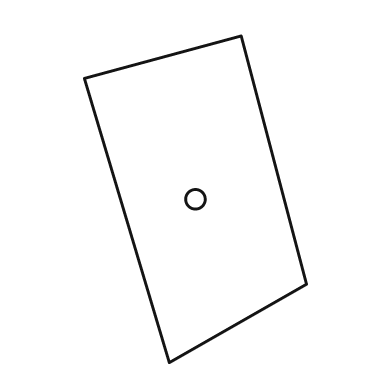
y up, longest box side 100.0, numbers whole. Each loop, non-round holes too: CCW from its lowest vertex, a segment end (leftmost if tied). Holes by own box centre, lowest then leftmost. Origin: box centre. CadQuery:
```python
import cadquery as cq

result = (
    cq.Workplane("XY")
    .moveTo(-8.0, -50.0)
    .lineTo(34.0, -26.0)
    .lineTo(14.0, 50.0)
    .lineTo(-34.0, 37.0)
    .close()
    .moveTo(0.0, 0.0)
    .circle(3.0)
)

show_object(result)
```